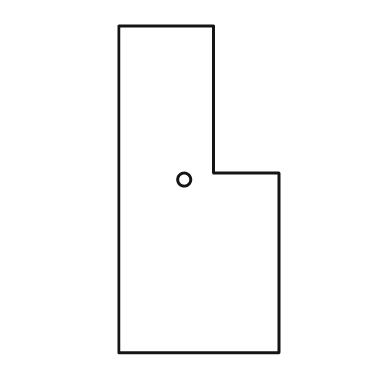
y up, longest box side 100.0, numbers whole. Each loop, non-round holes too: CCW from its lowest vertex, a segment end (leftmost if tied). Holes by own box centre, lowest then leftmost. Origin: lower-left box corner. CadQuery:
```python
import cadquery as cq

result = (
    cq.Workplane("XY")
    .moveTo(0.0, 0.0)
    .lineTo(49.0, 0.0)
    .lineTo(49.0, 55.0)
    .lineTo(29.0, 55.0)
    .lineTo(29.0, 100.0)
    .lineTo(0.0, 100.0)
    .close()
    .moveTo(20.0, 53.0)
    .circle(2.0)
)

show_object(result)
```